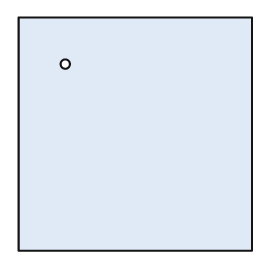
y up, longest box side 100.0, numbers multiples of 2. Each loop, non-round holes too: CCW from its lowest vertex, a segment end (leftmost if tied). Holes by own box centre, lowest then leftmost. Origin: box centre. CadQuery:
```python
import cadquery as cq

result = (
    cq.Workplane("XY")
    .moveTo(-50.0, -50.0)
    .lineTo(50.0, -50.0)
    .lineTo(50.0, 50.0)
    .lineTo(-50.0, 50.0)
    .close()
    .moveTo(-30.0, 30.0)
    .circle(2.0)
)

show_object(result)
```